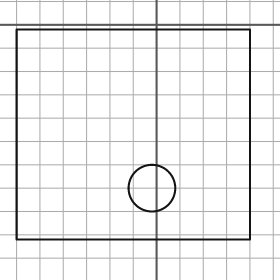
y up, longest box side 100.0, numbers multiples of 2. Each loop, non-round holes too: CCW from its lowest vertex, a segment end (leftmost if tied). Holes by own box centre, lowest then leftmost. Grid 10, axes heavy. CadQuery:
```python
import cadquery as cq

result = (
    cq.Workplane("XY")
    .moveTo(-60.0, -92.0)
    .lineTo(40.0, -92.0)
    .lineTo(40.0, -2.0)
    .lineTo(-60.0, -2.0)
    .close()
    .moveTo(-2.0, -70.0)
    .circle(10.0)
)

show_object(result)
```